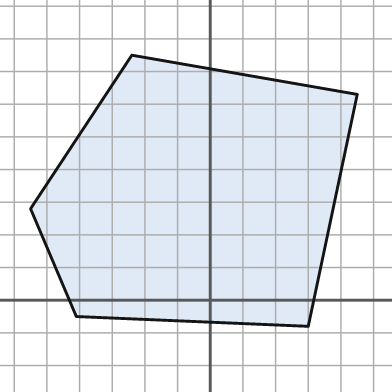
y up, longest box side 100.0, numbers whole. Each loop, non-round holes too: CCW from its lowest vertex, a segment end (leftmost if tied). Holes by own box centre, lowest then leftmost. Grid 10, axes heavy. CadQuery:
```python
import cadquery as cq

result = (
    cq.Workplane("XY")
    .moveTo(30.0, -8.0)
    .lineTo(45.0, 63.0)
    .lineTo(-24.0, 75.0)
    .lineTo(-55.0, 28.0)
    .lineTo(-41.0, -5.0)
    .close()
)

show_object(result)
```